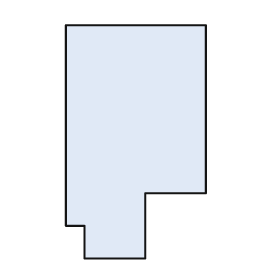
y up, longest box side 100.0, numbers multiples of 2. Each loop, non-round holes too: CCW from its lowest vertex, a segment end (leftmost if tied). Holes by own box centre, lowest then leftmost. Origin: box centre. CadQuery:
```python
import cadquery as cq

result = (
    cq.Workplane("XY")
    .moveTo(-22.0, -50.0)
    .lineTo(4.0, -50.0)
    .lineTo(4.0, -22.0)
    .lineTo(30.0, -22.0)
    .lineTo(30.0, 50.0)
    .lineTo(-30.0, 50.0)
    .lineTo(-30.0, -36.0)
    .lineTo(-22.0, -36.0)
    .close()
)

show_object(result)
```